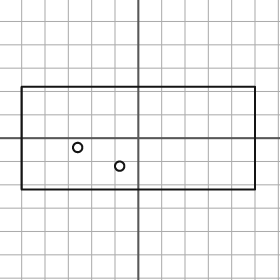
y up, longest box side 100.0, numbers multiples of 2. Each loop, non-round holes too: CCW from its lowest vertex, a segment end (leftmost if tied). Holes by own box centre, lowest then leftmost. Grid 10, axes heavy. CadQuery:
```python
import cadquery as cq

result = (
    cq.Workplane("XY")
    .moveTo(-50.0, -22.0)
    .lineTo(50.0, -22.0)
    .lineTo(50.0, 22.0)
    .lineTo(-50.0, 22.0)
    .close()
    .moveTo(-8.0, -12.0)
    .circle(2.0)
    .moveTo(-26.0, -4.0)
    .circle(2.0)
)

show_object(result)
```